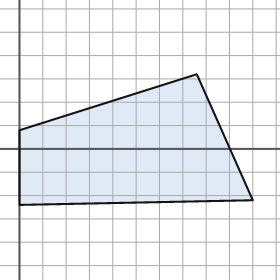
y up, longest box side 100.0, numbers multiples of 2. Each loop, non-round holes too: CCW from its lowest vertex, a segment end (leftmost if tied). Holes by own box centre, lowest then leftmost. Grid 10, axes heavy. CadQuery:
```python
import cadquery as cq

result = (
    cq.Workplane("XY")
    .moveTo(0.0, -24.0)
    .lineTo(100.0, -22.0)
    .lineTo(76.0, 32.0)
    .lineTo(0.0, 8.0)
    .close()
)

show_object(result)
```